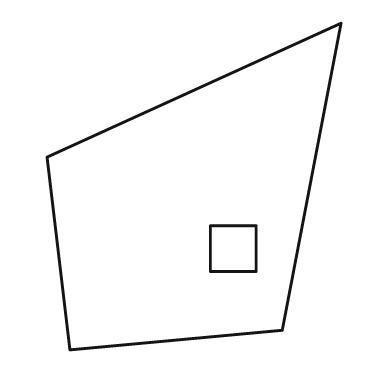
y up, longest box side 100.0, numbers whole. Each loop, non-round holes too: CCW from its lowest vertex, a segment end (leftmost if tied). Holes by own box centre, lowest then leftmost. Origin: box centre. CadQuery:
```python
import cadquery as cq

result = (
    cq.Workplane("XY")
    .moveTo(-38.0, -50.0)
    .lineTo(27.0, -44.0)
    .lineTo(45.0, 50.0)
    .lineTo(-45.0, 9.0)
    .close()
    .moveTo(5.0, -26.0)
    .lineTo(19.0, -26.0)
    .lineTo(19.0, -12.0)
    .lineTo(5.0, -12.0)
    .close()
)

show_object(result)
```